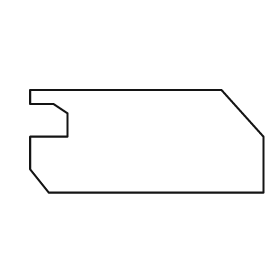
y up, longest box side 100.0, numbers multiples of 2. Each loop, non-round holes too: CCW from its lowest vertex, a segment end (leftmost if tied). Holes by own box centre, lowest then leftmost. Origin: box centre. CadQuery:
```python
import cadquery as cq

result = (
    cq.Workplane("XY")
    .moveTo(-42.0, -22.0)
    .lineTo(50.0, -22.0)
    .lineTo(50.0, 2.0)
    .lineTo(32.0, 22.0)
    .lineTo(-50.0, 22.0)
    .lineTo(-50.0, 16.0)
    .lineTo(-40.0, 16.0)
    .lineTo(-34.0, 12.0)
    .lineTo(-34.0, 2.0)
    .lineTo(-50.0, 2.0)
    .lineTo(-50.0, -12.0)
    .close()
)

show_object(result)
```